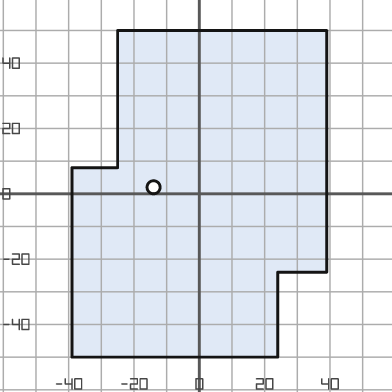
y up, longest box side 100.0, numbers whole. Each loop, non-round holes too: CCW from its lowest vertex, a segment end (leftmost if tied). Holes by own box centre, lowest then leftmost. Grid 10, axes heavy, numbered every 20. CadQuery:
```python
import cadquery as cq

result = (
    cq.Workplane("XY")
    .moveTo(-39.0, -50.0)
    .lineTo(24.0, -50.0)
    .lineTo(24.0, -24.0)
    .lineTo(39.0, -24.0)
    .lineTo(39.0, 50.0)
    .lineTo(-25.0, 50.0)
    .lineTo(-25.0, 8.0)
    .lineTo(-39.0, 8.0)
    .close()
    .moveTo(-14.0, 2.0)
    .circle(2.0)
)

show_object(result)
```